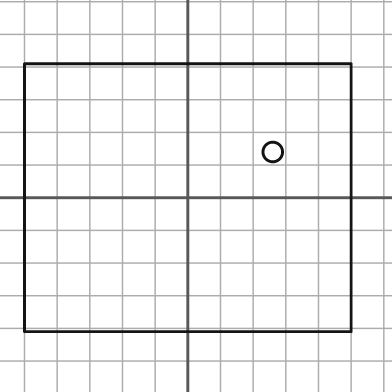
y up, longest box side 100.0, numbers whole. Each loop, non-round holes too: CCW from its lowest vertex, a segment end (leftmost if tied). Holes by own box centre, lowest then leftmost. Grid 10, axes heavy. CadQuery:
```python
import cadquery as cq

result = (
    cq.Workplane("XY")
    .moveTo(-50.0, -41.0)
    .lineTo(50.0, -41.0)
    .lineTo(50.0, 41.0)
    .lineTo(-50.0, 41.0)
    .close()
    .moveTo(26.0, 14.0)
    .circle(3.0)
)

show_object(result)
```